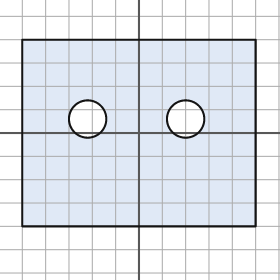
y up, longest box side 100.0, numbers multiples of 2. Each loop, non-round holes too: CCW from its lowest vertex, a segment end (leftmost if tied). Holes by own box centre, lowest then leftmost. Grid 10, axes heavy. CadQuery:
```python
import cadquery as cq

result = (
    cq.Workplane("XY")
    .moveTo(-50.0, -40.0)
    .lineTo(50.0, -40.0)
    .lineTo(50.0, 40.0)
    .lineTo(-50.0, 40.0)
    .close()
    .moveTo(-22.0, 6.0)
    .circle(8.0)
    .moveTo(20.0, 6.0)
    .circle(8.0)
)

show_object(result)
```